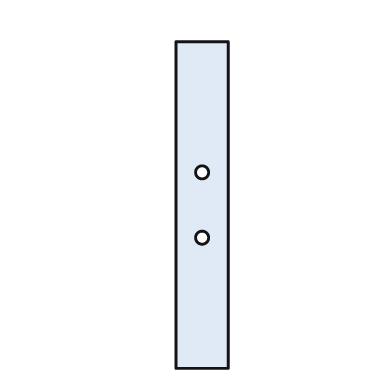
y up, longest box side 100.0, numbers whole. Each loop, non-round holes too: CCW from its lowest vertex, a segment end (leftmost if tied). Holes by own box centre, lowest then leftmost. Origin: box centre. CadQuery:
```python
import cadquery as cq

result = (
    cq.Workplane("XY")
    .moveTo(-8.0, -50.0)
    .lineTo(8.0, -50.0)
    .lineTo(8.0, 50.0)
    .lineTo(-8.0, 50.0)
    .close()
    .moveTo(0.0, -10.0)
    .circle(2.0)
    .moveTo(0.0, 10.0)
    .circle(2.0)
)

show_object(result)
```